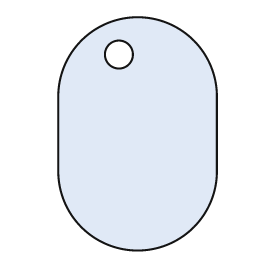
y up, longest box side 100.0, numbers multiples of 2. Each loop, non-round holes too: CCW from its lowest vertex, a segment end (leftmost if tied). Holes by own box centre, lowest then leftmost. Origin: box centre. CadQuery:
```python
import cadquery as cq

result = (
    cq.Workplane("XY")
    .moveTo(-34.0, -16.0)
    .threePointArc((0.0, -50.0), (34.0, -16.0))
    .lineTo(34.0, 16.0)
    .threePointArc((0.0, 50.0), (-34.0, 16.0))
    .close()
    .moveTo(-8.0, 34.0)
    .circle(6.0)
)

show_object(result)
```